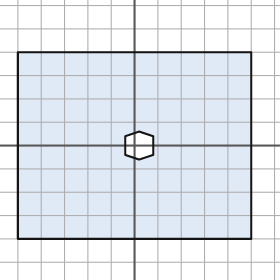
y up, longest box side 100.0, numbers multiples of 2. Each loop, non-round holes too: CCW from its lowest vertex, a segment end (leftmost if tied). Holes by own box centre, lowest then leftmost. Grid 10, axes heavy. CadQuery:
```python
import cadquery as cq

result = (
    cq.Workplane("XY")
    .moveTo(-50.0, -40.0)
    .lineTo(50.0, -40.0)
    .lineTo(50.0, 40.0)
    .lineTo(-50.0, 40.0)
    .close()
    .moveTo(2.0, -6.0)
    .lineTo(8.0, -4.0)
    .lineTo(8.0, 4.0)
    .lineTo(2.0, 6.0)
    .lineTo(-4.0, 4.0)
    .lineTo(-4.0, -4.0)
    .close()
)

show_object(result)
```